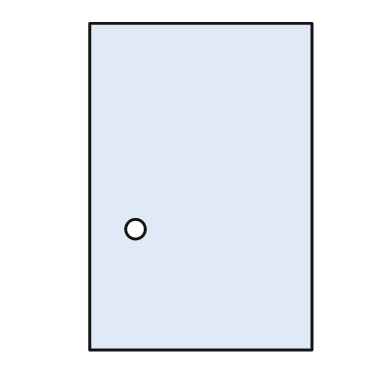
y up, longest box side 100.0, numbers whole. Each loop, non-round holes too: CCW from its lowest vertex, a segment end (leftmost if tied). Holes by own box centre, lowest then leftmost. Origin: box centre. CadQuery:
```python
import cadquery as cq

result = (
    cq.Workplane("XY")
    .moveTo(-34.0, -50.0)
    .lineTo(34.0, -50.0)
    .lineTo(34.0, 50.0)
    .lineTo(-34.0, 50.0)
    .close()
    .moveTo(-20.0, -13.0)
    .circle(3.0)
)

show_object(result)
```